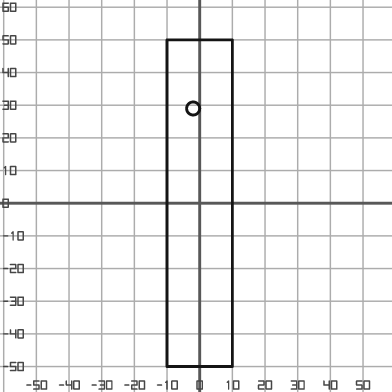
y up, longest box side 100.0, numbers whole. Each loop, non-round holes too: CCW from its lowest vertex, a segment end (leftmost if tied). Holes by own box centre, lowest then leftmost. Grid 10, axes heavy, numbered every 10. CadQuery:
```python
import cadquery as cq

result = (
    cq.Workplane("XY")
    .moveTo(-10.0, -50.0)
    .lineTo(10.0, -50.0)
    .lineTo(10.0, 50.0)
    .lineTo(-10.0, 50.0)
    .close()
    .moveTo(-2.0, 29.0)
    .circle(2.0)
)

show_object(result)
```